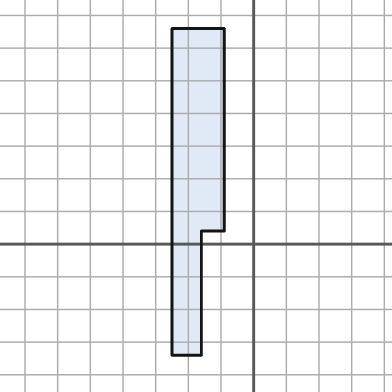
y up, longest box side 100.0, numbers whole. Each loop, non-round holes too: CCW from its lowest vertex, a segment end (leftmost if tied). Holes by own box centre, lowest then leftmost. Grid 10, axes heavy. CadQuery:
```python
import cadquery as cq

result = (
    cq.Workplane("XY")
    .moveTo(-25.0, -34.0)
    .lineTo(-16.0, -34.0)
    .lineTo(-16.0, 4.0)
    .lineTo(-9.0, 4.0)
    .lineTo(-9.0, 66.0)
    .lineTo(-25.0, 66.0)
    .close()
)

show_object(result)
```